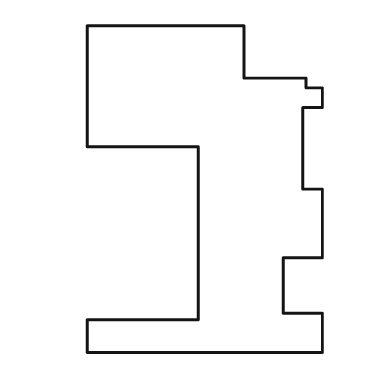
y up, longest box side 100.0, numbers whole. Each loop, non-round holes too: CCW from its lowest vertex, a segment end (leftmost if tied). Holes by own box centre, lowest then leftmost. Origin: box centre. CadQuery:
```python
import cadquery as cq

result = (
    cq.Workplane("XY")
    .moveTo(-36.0, -50.0)
    .lineTo(36.0, -50.0)
    .lineTo(36.0, -38.0)
    .lineTo(24.0, -38.0)
    .lineTo(24.0, -21.0)
    .lineTo(36.0, -21.0)
    .lineTo(36.0, 0.0)
    .lineTo(30.0, 0.0)
    .lineTo(30.0, 25.0)
    .lineTo(36.0, 25.0)
    .lineTo(36.0, 31.0)
    .lineTo(31.0, 31.0)
    .lineTo(31.0, 34.0)
    .lineTo(12.0, 34.0)
    .lineTo(12.0, 50.0)
    .lineTo(-36.0, 50.0)
    .lineTo(-36.0, 13.0)
    .lineTo(-2.0, 13.0)
    .lineTo(-2.0, -40.0)
    .lineTo(-36.0, -40.0)
    .close()
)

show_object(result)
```